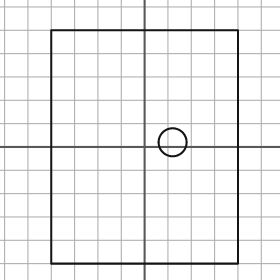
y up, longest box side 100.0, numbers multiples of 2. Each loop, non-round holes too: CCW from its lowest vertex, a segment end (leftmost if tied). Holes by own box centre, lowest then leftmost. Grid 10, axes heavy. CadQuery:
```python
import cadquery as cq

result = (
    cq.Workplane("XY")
    .moveTo(-40.0, -50.0)
    .lineTo(40.0, -50.0)
    .lineTo(40.0, 50.0)
    .lineTo(-40.0, 50.0)
    .close()
    .moveTo(12.0, 2.0)
    .circle(6.0)
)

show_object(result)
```